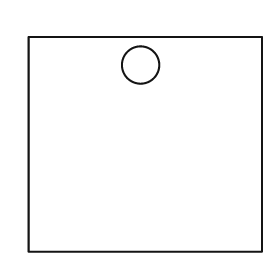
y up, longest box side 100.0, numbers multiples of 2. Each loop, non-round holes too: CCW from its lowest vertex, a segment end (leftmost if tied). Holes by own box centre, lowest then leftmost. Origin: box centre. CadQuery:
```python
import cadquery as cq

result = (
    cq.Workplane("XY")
    .moveTo(-50.0, -46.0)
    .lineTo(50.0, -46.0)
    .lineTo(50.0, 46.0)
    .lineTo(-50.0, 46.0)
    .close()
    .moveTo(-2.0, 34.0)
    .circle(8.0)
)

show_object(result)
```